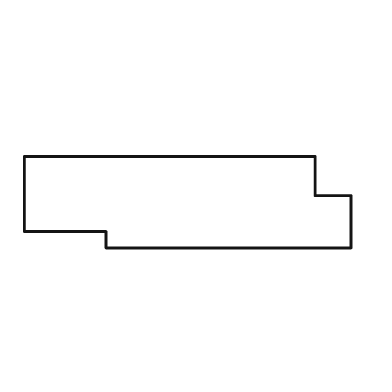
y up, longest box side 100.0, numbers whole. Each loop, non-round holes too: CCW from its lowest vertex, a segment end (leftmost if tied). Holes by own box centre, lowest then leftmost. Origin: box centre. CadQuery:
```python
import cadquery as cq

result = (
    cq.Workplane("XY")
    .moveTo(-25.0, -14.0)
    .lineTo(50.0, -14.0)
    .lineTo(50.0, 2.0)
    .lineTo(39.0, 2.0)
    .lineTo(39.0, 14.0)
    .lineTo(-50.0, 14.0)
    .lineTo(-50.0, -9.0)
    .lineTo(-25.0, -9.0)
    .close()
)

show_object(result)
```